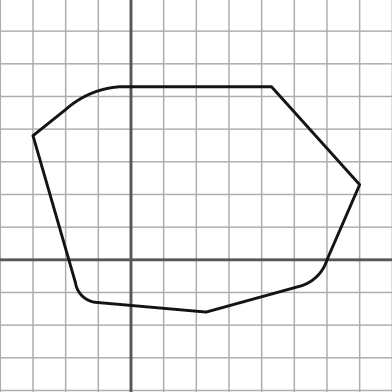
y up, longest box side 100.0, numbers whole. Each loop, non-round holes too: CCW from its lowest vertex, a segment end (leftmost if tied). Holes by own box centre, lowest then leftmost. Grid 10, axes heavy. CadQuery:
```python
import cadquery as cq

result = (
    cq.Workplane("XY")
    .moveTo(23.0, -16.0)
    .lineTo(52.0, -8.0)
    .threePointArc((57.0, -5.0), (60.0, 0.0))
    .lineTo(70.0, 23.0)
    .lineTo(43.0, 53.0)
    .lineTo(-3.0, 53.0)
    .threePointArc((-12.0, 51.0), (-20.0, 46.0))
    .lineTo(-30.0, 38.0)
    .lineTo(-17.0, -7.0)
    .threePointArc((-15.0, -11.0), (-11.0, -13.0))
    .close()
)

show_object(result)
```